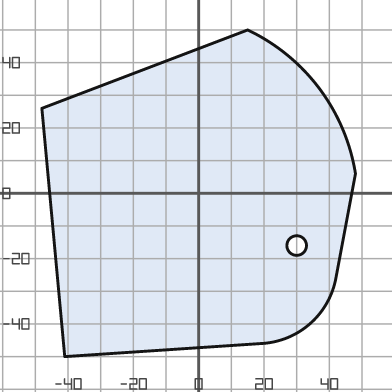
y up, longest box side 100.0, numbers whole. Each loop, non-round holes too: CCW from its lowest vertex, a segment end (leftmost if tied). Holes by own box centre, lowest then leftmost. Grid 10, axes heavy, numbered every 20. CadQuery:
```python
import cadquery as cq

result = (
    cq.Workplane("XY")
    .moveTo(-41.0, -50.0)
    .lineTo(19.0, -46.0)
    .threePointArc((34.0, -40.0), (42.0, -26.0))
    .lineTo(48.0, 6.0)
    .threePointArc((37.0, 32.0), (15.0, 50.0))
    .lineTo(-48.0, 26.0)
    .close()
    .moveTo(30.0, -16.0)
    .circle(3.0)
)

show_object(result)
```